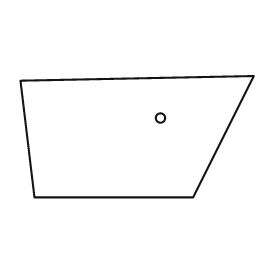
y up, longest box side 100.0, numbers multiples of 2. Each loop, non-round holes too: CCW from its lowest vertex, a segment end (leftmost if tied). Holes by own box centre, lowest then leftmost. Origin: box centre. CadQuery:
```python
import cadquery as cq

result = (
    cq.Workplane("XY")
    .moveTo(-44.0, -26.0)
    .lineTo(24.0, -26.0)
    .lineTo(50.0, 26.0)
    .lineTo(-50.0, 24.0)
    .close()
    .moveTo(10.0, 8.0)
    .circle(2.0)
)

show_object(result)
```